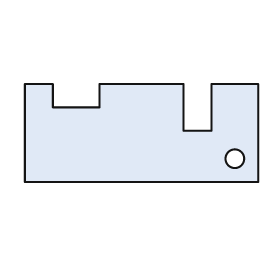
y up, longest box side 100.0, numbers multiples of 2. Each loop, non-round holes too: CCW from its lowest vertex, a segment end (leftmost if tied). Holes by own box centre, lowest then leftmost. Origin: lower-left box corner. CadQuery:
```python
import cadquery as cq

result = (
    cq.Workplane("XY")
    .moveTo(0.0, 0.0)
    .lineTo(100.0, 0.0)
    .lineTo(100.0, 42.0)
    .lineTo(80.0, 42.0)
    .lineTo(80.0, 22.0)
    .lineTo(68.0, 22.0)
    .lineTo(68.0, 42.0)
    .lineTo(32.0, 42.0)
    .lineTo(32.0, 32.0)
    .lineTo(12.0, 32.0)
    .lineTo(12.0, 42.0)
    .lineTo(0.0, 42.0)
    .close()
    .moveTo(90.0, 10.0)
    .circle(4.0)
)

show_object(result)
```